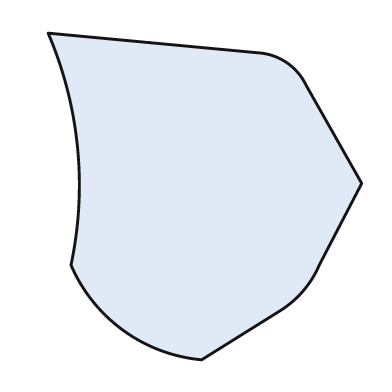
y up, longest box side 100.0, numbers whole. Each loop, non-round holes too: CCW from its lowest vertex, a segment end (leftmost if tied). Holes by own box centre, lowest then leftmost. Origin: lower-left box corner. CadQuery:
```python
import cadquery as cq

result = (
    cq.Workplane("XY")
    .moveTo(47.0, 0.0)
    .lineTo(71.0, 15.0)
    .threePointArc((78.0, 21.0), (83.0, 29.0))
    .lineTo(96.0, 54.0)
    .lineTo(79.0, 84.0)
    .threePointArc((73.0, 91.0), (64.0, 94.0))
    .lineTo(0.0, 100.0)
    .threePointArc((9.0, 65.0), (7.0, 29.0))
    .threePointArc((23.0, 9.0), (47.0, 0.0))
    .close()
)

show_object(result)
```